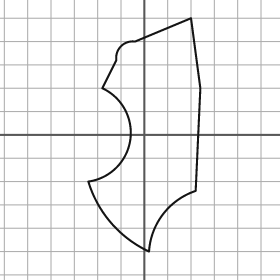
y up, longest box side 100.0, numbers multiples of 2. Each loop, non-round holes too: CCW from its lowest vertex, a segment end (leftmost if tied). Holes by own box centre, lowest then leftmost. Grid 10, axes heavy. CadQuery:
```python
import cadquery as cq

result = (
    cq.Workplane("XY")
    .moveTo(2.0, -50.0)
    .threePointArc((8.0, -34.0), (22.0, -24.0))
    .lineTo(24.0, 20.0)
    .lineTo(20.0, 50.0)
    .lineTo(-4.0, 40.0)
    .threePointArc((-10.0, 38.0), (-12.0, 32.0))
    .lineTo(-18.0, 20.0)
    .threePointArc((-6.0, -2.0), (-24.0, -20.0))
    .threePointArc((-14.0, -38.0), (2.0, -50.0))
    .close()
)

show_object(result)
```